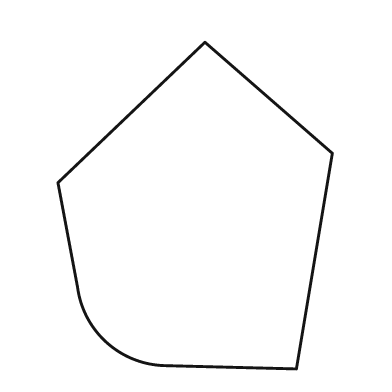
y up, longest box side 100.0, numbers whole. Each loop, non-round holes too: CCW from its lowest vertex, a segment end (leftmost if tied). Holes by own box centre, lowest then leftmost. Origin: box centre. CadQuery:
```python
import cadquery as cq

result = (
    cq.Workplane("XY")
    .moveTo(31.0, -50.0)
    .lineTo(42.0, 16.0)
    .lineTo(3.0, 50.0)
    .lineTo(-42.0, 7.0)
    .lineTo(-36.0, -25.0)
    .threePointArc((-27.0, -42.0), (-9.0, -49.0))
    .close()
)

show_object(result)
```